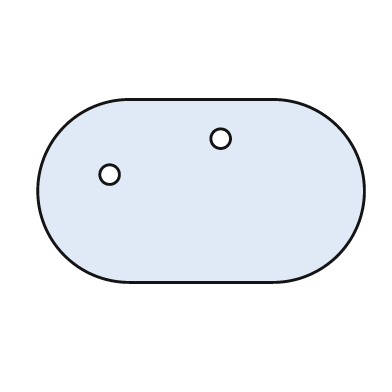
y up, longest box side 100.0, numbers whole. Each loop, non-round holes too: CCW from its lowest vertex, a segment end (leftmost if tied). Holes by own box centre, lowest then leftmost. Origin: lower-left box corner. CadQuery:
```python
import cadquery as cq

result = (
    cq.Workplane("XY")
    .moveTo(28.0, 0.0)
    .lineTo(72.0, 0.0)
    .threePointArc((100.0, 28.0), (72.0, 56.0))
    .lineTo(28.0, 56.0)
    .threePointArc((0.0, 28.0), (28.0, 0.0))
    .close()
    .moveTo(22.0, 33.0)
    .circle(3.0)
    .moveTo(56.0, 44.0)
    .circle(3.0)
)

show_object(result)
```